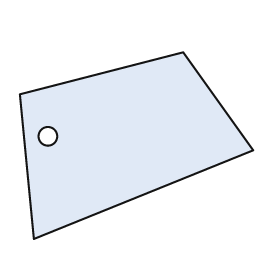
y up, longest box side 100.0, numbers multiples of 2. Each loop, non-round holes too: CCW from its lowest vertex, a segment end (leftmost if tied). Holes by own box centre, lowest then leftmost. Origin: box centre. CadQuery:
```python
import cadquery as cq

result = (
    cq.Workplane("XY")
    .moveTo(-44.0, -40.0)
    .lineTo(50.0, -2.0)
    .lineTo(20.0, 40.0)
    .lineTo(-50.0, 22.0)
    .close()
    .moveTo(-38.0, 4.0)
    .circle(4.0)
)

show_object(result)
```